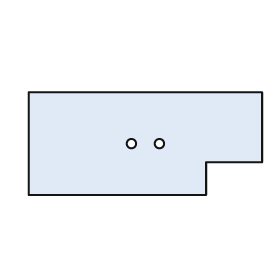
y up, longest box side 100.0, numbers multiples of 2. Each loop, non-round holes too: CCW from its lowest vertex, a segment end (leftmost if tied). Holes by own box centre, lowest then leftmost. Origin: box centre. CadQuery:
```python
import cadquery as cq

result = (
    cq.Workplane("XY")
    .moveTo(-50.0, -22.0)
    .lineTo(26.0, -22.0)
    .lineTo(26.0, -8.0)
    .lineTo(50.0, -8.0)
    .lineTo(50.0, 22.0)
    .lineTo(-50.0, 22.0)
    .close()
    .moveTo(-6.0, 0.0)
    .circle(2.0)
    .moveTo(6.0, 0.0)
    .circle(2.0)
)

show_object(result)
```